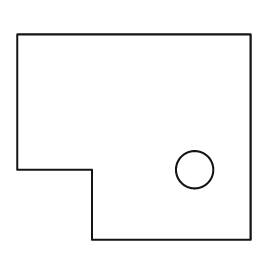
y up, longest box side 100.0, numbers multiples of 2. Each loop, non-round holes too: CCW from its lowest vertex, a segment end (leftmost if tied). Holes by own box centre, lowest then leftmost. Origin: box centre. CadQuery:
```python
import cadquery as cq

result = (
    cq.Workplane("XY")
    .moveTo(-18.0, -44.0)
    .lineTo(50.0, -44.0)
    .lineTo(50.0, 44.0)
    .lineTo(-50.0, 44.0)
    .lineTo(-50.0, -14.0)
    .lineTo(-18.0, -14.0)
    .close()
    .moveTo(26.0, -14.0)
    .circle(8.0)
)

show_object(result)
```